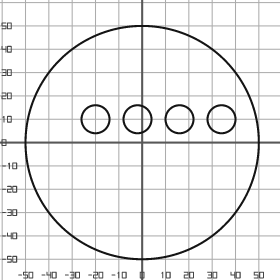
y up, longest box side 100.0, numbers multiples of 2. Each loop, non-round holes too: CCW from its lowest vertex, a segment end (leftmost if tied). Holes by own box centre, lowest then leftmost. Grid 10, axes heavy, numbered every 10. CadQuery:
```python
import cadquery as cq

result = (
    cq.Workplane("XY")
    .moveTo(0.0, 0.0)
    .circle(50.0)
    .moveTo(-20.0, 10.0)
    .circle(6.0)
    .moveTo(-2.0, 10.0)
    .circle(6.0)
    .moveTo(16.0, 10.0)
    .circle(6.0)
    .moveTo(34.0, 10.0)
    .circle(6.0)
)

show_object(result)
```